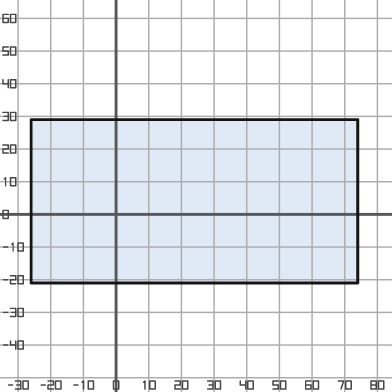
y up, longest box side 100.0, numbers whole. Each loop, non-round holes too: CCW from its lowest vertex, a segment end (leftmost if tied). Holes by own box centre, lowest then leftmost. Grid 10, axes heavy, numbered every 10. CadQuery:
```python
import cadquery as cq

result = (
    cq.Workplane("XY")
    .moveTo(-26.0, -21.0)
    .lineTo(74.0, -21.0)
    .lineTo(74.0, 29.0)
    .lineTo(-26.0, 29.0)
    .close()
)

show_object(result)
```